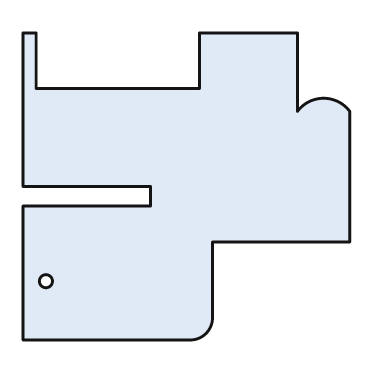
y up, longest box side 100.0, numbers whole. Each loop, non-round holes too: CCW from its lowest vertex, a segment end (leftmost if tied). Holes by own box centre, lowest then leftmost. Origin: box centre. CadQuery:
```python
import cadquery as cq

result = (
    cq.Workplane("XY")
    .moveTo(-50.0, -47.0)
    .lineTo(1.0, -47.0)
    .threePointArc((6.0, -45.0), (8.0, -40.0))
    .lineTo(8.0, -17.0)
    .lineTo(50.0, -17.0)
    .lineTo(50.0, 23.0)
    .threePointArc((42.0, 27.0), (34.0, 23.0))
    .lineTo(34.0, 47.0)
    .lineTo(4.0, 47.0)
    .lineTo(4.0, 30.0)
    .lineTo(-46.0, 30.0)
    .lineTo(-46.0, 47.0)
    .lineTo(-50.0, 47.0)
    .lineTo(-50.0, 0.0)
    .lineTo(-11.0, 0.0)
    .lineTo(-11.0, -6.0)
    .lineTo(-50.0, -6.0)
    .close()
    .moveTo(-43.0, -29.0)
    .circle(2.0)
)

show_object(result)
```